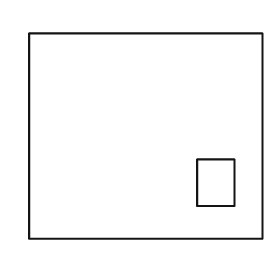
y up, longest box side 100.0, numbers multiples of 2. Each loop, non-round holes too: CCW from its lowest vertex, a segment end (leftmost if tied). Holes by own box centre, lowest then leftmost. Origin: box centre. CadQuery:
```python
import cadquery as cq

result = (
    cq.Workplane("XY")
    .moveTo(-50.0, -44.0)
    .lineTo(50.0, -44.0)
    .lineTo(50.0, 44.0)
    .lineTo(-50.0, 44.0)
    .close()
    .moveTo(22.0, -30.0)
    .lineTo(38.0, -30.0)
    .lineTo(38.0, -10.0)
    .lineTo(22.0, -10.0)
    .close()
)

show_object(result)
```